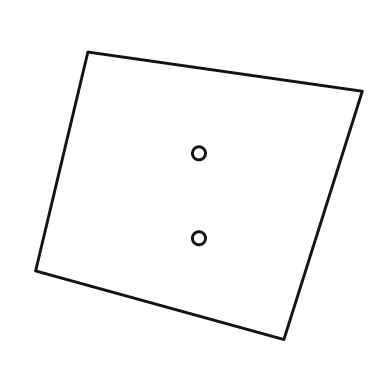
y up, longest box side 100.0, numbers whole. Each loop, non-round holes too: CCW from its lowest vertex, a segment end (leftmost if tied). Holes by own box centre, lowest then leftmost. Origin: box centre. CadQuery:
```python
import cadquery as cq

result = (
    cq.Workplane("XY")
    .moveTo(26.0, -44.0)
    .lineTo(50.0, 32.0)
    .lineTo(-34.0, 44.0)
    .lineTo(-50.0, -23.0)
    .close()
    .moveTo(0.0, -13.0)
    .circle(2.0)
    .moveTo(0.0, 13.0)
    .circle(2.0)
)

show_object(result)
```